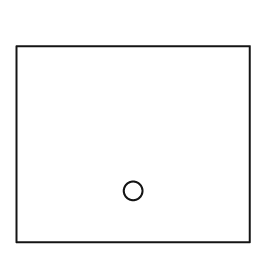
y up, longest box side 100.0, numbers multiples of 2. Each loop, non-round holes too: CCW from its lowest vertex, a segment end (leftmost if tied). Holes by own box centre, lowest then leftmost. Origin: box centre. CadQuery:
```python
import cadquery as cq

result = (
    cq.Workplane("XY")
    .moveTo(-50.0, -42.0)
    .lineTo(50.0, -42.0)
    .lineTo(50.0, 42.0)
    .lineTo(-50.0, 42.0)
    .close()
    .moveTo(0.0, -20.0)
    .circle(4.0)
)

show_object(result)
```